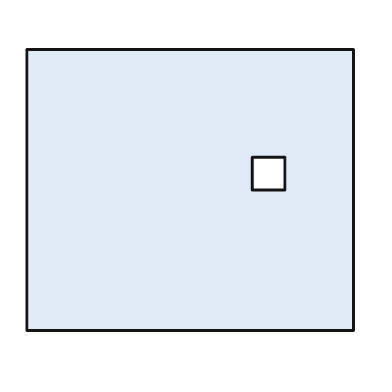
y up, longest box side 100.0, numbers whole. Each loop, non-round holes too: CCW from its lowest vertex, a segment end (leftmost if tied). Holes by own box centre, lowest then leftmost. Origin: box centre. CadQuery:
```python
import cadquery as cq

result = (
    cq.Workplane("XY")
    .moveTo(-50.0, -43.0)
    .lineTo(50.0, -43.0)
    .lineTo(50.0, 43.0)
    .lineTo(-50.0, 43.0)
    .close()
    .moveTo(19.0, 0.0)
    .lineTo(29.0, 0.0)
    .lineTo(29.0, 10.0)
    .lineTo(19.0, 10.0)
    .close()
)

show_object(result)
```